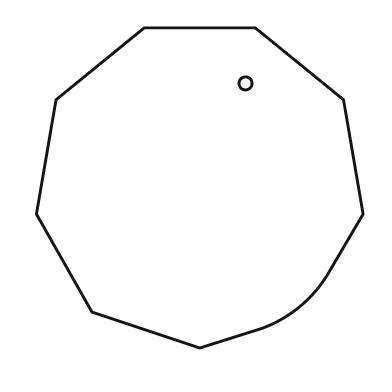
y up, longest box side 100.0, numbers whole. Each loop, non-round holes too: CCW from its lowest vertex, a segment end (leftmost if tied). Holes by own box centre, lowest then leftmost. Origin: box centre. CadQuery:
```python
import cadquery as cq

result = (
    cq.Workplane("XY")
    .moveTo(0.0, -49.0)
    .lineTo(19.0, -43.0)
    .threePointArc((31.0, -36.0), (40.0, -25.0))
    .lineTo(50.0, -8.0)
    .lineTo(44.0, 27.0)
    .lineTo(17.0, 49.0)
    .lineTo(-17.0, 49.0)
    .lineTo(-44.0, 27.0)
    .lineTo(-50.0, -8.0)
    .lineTo(-33.0, -38.0)
    .close()
    .moveTo(14.0, 32.0)
    .circle(2.0)
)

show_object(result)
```